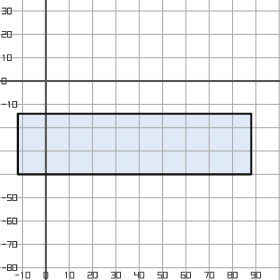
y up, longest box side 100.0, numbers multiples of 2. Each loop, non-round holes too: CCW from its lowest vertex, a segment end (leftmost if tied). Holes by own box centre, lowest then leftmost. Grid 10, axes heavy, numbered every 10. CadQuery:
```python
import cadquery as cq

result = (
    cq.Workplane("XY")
    .moveTo(-12.0, -40.0)
    .lineTo(88.0, -40.0)
    .lineTo(88.0, -14.0)
    .lineTo(-12.0, -14.0)
    .close()
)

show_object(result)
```